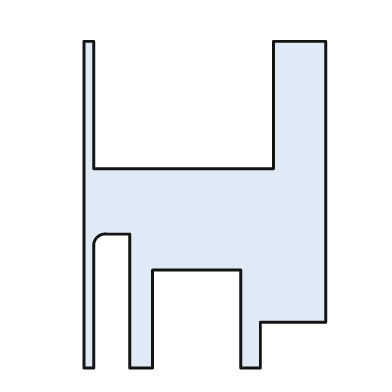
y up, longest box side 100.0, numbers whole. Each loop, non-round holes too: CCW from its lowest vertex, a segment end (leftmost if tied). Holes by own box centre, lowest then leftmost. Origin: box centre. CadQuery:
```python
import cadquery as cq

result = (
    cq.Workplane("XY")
    .moveTo(-37.0, -50.0)
    .lineTo(-34.0, -50.0)
    .lineTo(-34.0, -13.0)
    .threePointArc((-33.0, -10.0), (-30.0, -9.0))
    .lineTo(-23.0, -9.0)
    .lineTo(-23.0, -50.0)
    .lineTo(-16.0, -50.0)
    .lineTo(-16.0, -20.0)
    .lineTo(11.0, -20.0)
    .lineTo(11.0, -50.0)
    .lineTo(17.0, -50.0)
    .lineTo(17.0, -36.0)
    .lineTo(37.0, -36.0)
    .lineTo(37.0, 50.0)
    .lineTo(21.0, 50.0)
    .lineTo(21.0, 11.0)
    .lineTo(-34.0, 11.0)
    .lineTo(-34.0, 50.0)
    .lineTo(-37.0, 50.0)
    .close()
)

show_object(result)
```